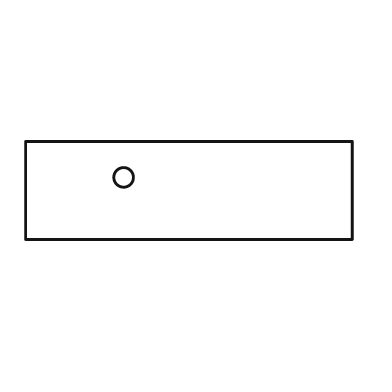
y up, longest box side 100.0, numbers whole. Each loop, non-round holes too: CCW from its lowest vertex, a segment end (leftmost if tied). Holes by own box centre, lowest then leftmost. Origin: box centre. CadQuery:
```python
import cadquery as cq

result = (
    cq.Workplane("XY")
    .moveTo(-50.0, -15.0)
    .lineTo(50.0, -15.0)
    .lineTo(50.0, 15.0)
    .lineTo(-50.0, 15.0)
    .close()
    .moveTo(-20.0, 4.0)
    .circle(3.0)
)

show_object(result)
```